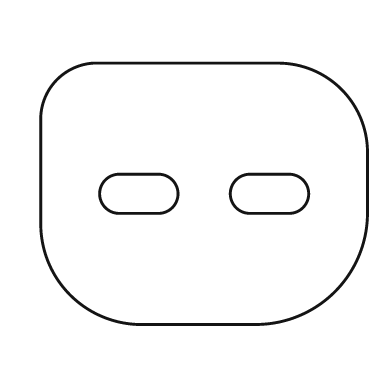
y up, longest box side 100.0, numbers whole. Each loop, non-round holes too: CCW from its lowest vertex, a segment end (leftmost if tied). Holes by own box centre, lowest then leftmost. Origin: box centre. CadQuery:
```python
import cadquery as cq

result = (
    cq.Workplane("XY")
    .moveTo(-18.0, -40.0)
    .lineTo(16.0, -40.0)
    .threePointArc((40.0, -30.0), (50.0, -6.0))
    .lineTo(50.0, 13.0)
    .threePointArc((42.0, 32.0), (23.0, 40.0))
    .lineTo(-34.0, 40.0)
    .threePointArc((-45.0, 35.0), (-50.0, 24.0))
    .lineTo(-50.0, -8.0)
    .threePointArc((-41.0, -31.0), (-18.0, -40.0))
    .close()
    .moveTo(-26.0, -6.0)
    .lineTo(-14.0, -6.0)
    .threePointArc((-8.0, 0.0), (-14.0, 6.0))
    .lineTo(-26.0, 6.0)
    .threePointArc((-32.0, 0.0), (-26.0, -6.0))
    .close()
    .moveTo(14.0, -6.0)
    .lineTo(26.0, -6.0)
    .threePointArc((32.0, 0.0), (26.0, 6.0))
    .lineTo(14.0, 6.0)
    .threePointArc((8.0, 0.0), (14.0, -6.0))
    .close()
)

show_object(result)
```